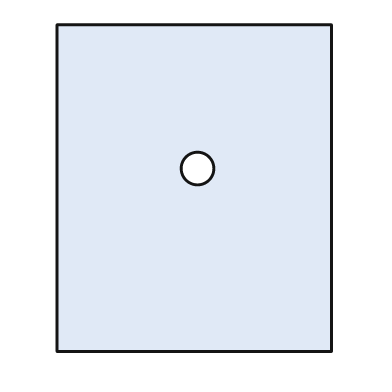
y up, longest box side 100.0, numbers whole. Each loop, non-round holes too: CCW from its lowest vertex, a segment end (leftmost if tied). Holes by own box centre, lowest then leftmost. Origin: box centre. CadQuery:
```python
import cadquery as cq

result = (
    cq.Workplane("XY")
    .moveTo(-42.0, -50.0)
    .lineTo(42.0, -50.0)
    .lineTo(42.0, 50.0)
    .lineTo(-42.0, 50.0)
    .close()
    .moveTo(1.0, 6.0)
    .circle(5.0)
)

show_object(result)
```